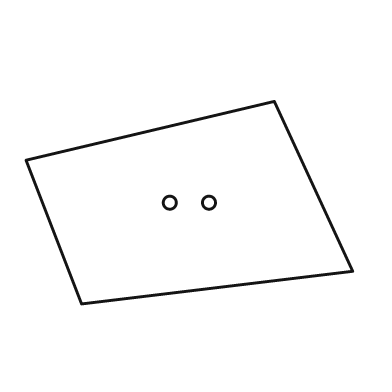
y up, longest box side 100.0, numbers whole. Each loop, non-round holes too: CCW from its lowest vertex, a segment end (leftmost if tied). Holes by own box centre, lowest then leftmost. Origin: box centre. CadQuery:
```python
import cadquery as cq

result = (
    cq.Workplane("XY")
    .moveTo(-33.0, -31.0)
    .lineTo(50.0, -21.0)
    .lineTo(26.0, 31.0)
    .lineTo(-50.0, 13.0)
    .close()
    .moveTo(-6.0, 0.0)
    .circle(2.0)
    .moveTo(6.0, 0.0)
    .circle(2.0)
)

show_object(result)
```